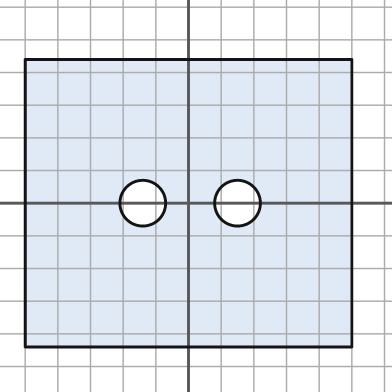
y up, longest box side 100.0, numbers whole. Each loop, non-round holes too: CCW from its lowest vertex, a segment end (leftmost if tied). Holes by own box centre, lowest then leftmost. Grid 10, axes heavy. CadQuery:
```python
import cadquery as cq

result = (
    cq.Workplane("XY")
    .moveTo(-50.0, -44.0)
    .lineTo(50.0, -44.0)
    .lineTo(50.0, 44.0)
    .lineTo(-50.0, 44.0)
    .close()
    .moveTo(-14.0, 0.0)
    .circle(7.0)
    .moveTo(15.0, 0.0)
    .circle(7.0)
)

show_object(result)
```